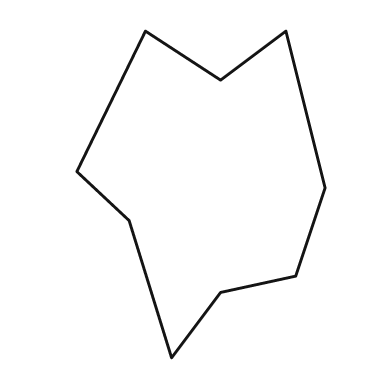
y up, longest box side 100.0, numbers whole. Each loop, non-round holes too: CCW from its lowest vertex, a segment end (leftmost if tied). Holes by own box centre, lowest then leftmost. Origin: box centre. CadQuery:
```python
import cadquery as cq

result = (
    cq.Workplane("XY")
    .moveTo(-9.0, -50.0)
    .lineTo(6.0, -30.0)
    .lineTo(29.0, -25.0)
    .lineTo(38.0, 2.0)
    .lineTo(26.0, 50.0)
    .lineTo(6.0, 35.0)
    .lineTo(-17.0, 50.0)
    .lineTo(-38.0, 7.0)
    .lineTo(-22.0, -8.0)
    .close()
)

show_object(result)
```